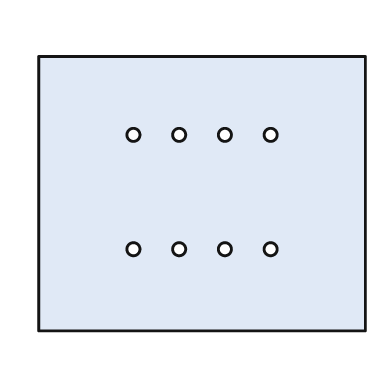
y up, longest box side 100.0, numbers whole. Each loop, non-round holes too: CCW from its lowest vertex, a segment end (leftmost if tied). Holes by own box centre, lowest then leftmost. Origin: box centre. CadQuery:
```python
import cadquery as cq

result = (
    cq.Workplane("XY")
    .moveTo(-50.0, -42.0)
    .lineTo(50.0, -42.0)
    .lineTo(50.0, 42.0)
    .lineTo(-50.0, 42.0)
    .close()
    .moveTo(-21.0, -17.0)
    .circle(2.0)
    .moveTo(-7.0, -17.0)
    .circle(2.0)
    .moveTo(7.0, -17.0)
    .circle(2.0)
    .moveTo(21.0, -17.0)
    .circle(2.0)
    .moveTo(-21.0, 18.0)
    .circle(2.0)
    .moveTo(-7.0, 18.0)
    .circle(2.0)
    .moveTo(7.0, 18.0)
    .circle(2.0)
    .moveTo(21.0, 18.0)
    .circle(2.0)
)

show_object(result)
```